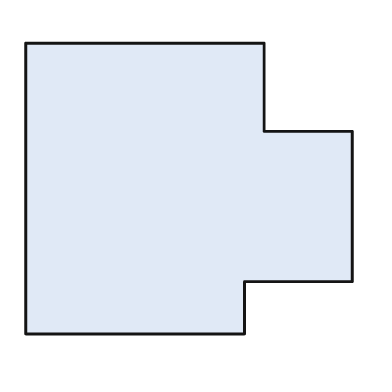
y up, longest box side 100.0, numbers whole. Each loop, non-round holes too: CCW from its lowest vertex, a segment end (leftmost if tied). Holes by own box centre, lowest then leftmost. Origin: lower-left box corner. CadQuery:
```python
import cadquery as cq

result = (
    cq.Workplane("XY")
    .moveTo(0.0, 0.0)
    .lineTo(67.0, 0.0)
    .lineTo(67.0, 16.0)
    .lineTo(100.0, 16.0)
    .lineTo(100.0, 62.0)
    .lineTo(73.0, 62.0)
    .lineTo(73.0, 89.0)
    .lineTo(0.0, 89.0)
    .close()
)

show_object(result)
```